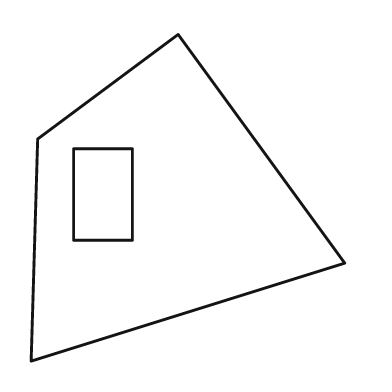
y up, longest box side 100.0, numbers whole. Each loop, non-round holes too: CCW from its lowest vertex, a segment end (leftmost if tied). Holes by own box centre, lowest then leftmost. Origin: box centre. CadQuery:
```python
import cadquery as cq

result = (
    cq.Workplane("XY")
    .moveTo(-48.0, -50.0)
    .lineTo(48.0, -20.0)
    .lineTo(-3.0, 50.0)
    .lineTo(-46.0, 18.0)
    .close()
    .moveTo(-35.0, -13.0)
    .lineTo(-17.0, -13.0)
    .lineTo(-17.0, 15.0)
    .lineTo(-35.0, 15.0)
    .close()
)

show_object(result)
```